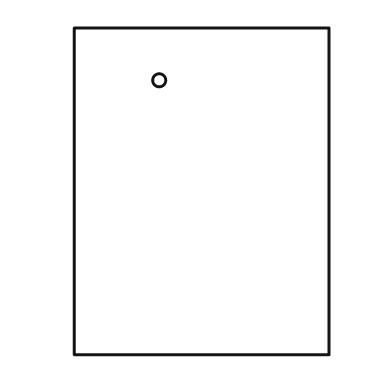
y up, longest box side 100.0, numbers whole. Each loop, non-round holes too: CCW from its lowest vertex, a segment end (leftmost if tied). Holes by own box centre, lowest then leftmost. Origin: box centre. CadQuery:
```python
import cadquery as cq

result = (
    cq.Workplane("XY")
    .moveTo(-39.0, -50.0)
    .lineTo(39.0, -50.0)
    .lineTo(39.0, 50.0)
    .lineTo(-39.0, 50.0)
    .close()
    .moveTo(-13.0, 34.0)
    .circle(2.0)
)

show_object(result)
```